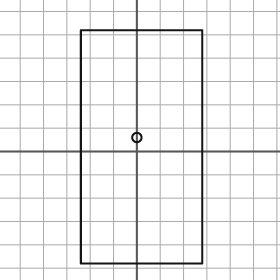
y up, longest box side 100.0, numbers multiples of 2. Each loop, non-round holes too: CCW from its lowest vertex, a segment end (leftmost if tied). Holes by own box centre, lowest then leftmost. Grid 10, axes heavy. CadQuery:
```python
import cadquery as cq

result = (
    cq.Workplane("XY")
    .moveTo(-24.0, -48.0)
    .lineTo(28.0, -48.0)
    .lineTo(28.0, 52.0)
    .lineTo(-24.0, 52.0)
    .close()
    .moveTo(0.0, 6.0)
    .circle(2.0)
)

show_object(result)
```